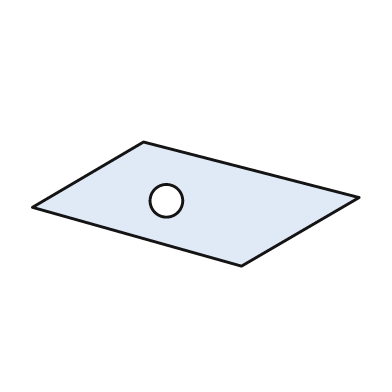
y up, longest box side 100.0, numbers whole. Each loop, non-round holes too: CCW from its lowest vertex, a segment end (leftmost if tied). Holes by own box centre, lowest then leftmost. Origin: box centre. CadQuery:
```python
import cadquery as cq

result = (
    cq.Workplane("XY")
    .moveTo(14.0, -19.0)
    .lineTo(50.0, 2.0)
    .lineTo(-16.0, 19.0)
    .lineTo(-50.0, -1.0)
    .close()
    .moveTo(-9.0, 1.0)
    .circle(5.0)
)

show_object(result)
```